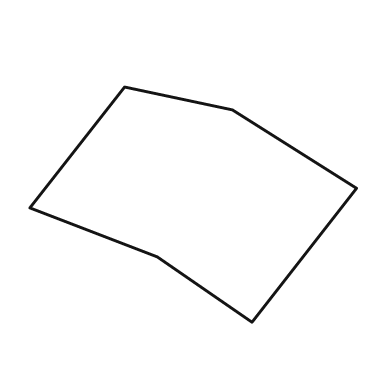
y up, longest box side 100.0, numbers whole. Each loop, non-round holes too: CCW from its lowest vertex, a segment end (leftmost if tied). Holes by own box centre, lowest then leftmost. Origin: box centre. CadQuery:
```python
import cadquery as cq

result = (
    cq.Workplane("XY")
    .moveTo(18.0, -36.0)
    .lineTo(50.0, 5.0)
    .lineTo(12.0, 29.0)
    .lineTo(-21.0, 36.0)
    .lineTo(-50.0, -1.0)
    .lineTo(-11.0, -16.0)
    .close()
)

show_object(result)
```